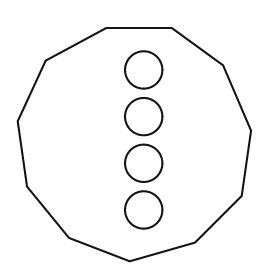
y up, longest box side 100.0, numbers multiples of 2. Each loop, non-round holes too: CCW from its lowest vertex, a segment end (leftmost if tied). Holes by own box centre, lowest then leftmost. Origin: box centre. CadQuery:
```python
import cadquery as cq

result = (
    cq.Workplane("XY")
    .moveTo(-2.0, -50.0)
    .lineTo(26.0, -42.0)
    .lineTo(46.0, -22.0)
    .lineTo(50.0, 6.0)
    .lineTo(38.0, 34.0)
    .lineTo(16.0, 50.0)
    .lineTo(-12.0, 50.0)
    .lineTo(-38.0, 36.0)
    .lineTo(-50.0, 10.0)
    .lineTo(-46.0, -18.0)
    .lineTo(-28.0, -40.0)
    .close()
    .moveTo(4.0, -28.0)
    .circle(8.0)
    .moveTo(4.0, -8.0)
    .circle(8.0)
    .moveTo(4.0, 12.0)
    .circle(8.0)
    .moveTo(4.0, 32.0)
    .circle(8.0)
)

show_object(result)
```